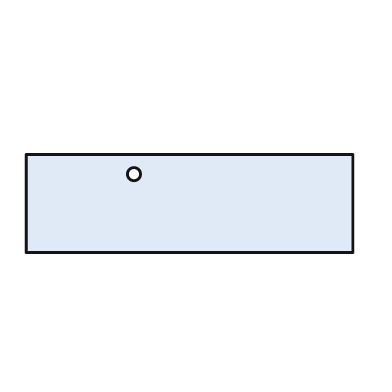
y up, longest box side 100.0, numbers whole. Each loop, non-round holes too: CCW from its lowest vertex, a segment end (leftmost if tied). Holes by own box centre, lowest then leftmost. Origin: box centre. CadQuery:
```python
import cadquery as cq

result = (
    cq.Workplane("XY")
    .moveTo(-50.0, -15.0)
    .lineTo(50.0, -15.0)
    .lineTo(50.0, 15.0)
    .lineTo(-50.0, 15.0)
    .close()
    .moveTo(-17.0, 9.0)
    .circle(2.0)
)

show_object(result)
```